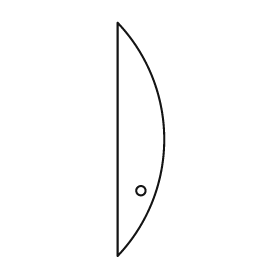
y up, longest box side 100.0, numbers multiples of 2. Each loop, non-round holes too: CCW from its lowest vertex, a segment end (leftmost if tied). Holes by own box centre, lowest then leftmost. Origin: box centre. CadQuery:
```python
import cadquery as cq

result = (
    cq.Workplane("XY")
    .moveTo(-10.0, -50.0)
    .threePointArc((10.0, 0.0), (-10.0, 50.0))
    .close()
    .moveTo(0.0, -22.0)
    .circle(2.0)
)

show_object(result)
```